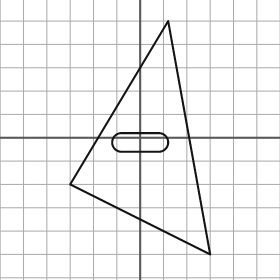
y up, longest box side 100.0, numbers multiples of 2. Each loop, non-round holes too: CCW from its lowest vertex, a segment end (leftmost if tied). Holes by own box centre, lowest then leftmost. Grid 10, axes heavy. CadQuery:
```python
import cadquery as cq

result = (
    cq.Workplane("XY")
    .moveTo(30.0, -50.0)
    .lineTo(12.0, 50.0)
    .lineTo(-30.0, -20.0)
    .close()
    .moveTo(-8.0, -6.0)
    .lineTo(8.0, -6.0)
    .threePointArc((12.0, -2.0), (8.0, 2.0))
    .lineTo(-8.0, 2.0)
    .threePointArc((-12.0, -2.0), (-8.0, -6.0))
    .close()
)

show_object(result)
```